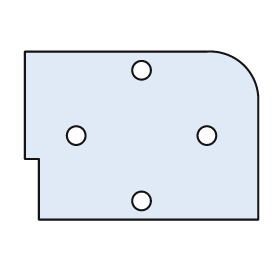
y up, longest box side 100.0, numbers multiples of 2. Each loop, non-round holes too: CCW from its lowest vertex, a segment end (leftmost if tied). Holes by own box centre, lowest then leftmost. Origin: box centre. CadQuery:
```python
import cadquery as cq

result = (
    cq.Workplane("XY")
    .moveTo(-44.0, -36.0)
    .lineTo(50.0, -36.0)
    .lineTo(50.0, 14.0)
    .threePointArc((44.0, 30.0), (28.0, 36.0))
    .lineTo(-50.0, 36.0)
    .lineTo(-50.0, -10.0)
    .lineTo(-44.0, -10.0)
    .close()
    .moveTo(0.0, -28.0)
    .circle(4.0)
    .moveTo(-28.0, 0.0)
    .circle(4.0)
    .moveTo(28.0, 0.0)
    .circle(4.0)
    .moveTo(0.0, 28.0)
    .circle(4.0)
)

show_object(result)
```